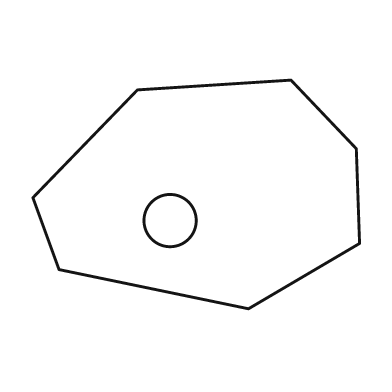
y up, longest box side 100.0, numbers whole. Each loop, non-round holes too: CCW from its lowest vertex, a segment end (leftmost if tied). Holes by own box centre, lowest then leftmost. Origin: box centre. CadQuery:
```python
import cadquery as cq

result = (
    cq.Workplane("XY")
    .moveTo(16.0, -35.0)
    .lineTo(50.0, -15.0)
    .lineTo(49.0, 14.0)
    .lineTo(29.0, 35.0)
    .lineTo(-18.0, 32.0)
    .lineTo(-50.0, -1.0)
    .lineTo(-42.0, -23.0)
    .close()
    .moveTo(-8.0, -8.0)
    .circle(8.0)
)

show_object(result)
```